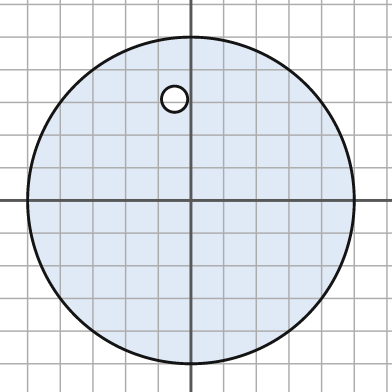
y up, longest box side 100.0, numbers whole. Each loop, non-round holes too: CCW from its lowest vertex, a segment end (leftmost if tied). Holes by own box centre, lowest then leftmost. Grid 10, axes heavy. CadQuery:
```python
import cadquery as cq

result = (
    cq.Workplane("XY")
    .moveTo(0.0, 0.0)
    .circle(50.0)
    .moveTo(-5.0, 31.0)
    .circle(4.0)
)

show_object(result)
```